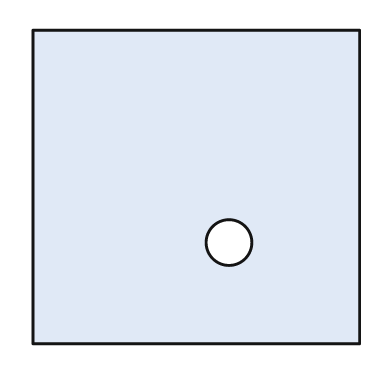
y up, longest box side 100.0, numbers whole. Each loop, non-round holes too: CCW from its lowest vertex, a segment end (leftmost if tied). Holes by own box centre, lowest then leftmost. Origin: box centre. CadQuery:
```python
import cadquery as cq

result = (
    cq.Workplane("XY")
    .moveTo(-50.0, -48.0)
    .lineTo(50.0, -48.0)
    .lineTo(50.0, 48.0)
    .lineTo(-50.0, 48.0)
    .close()
    .moveTo(10.0, -17.0)
    .circle(7.0)
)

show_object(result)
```